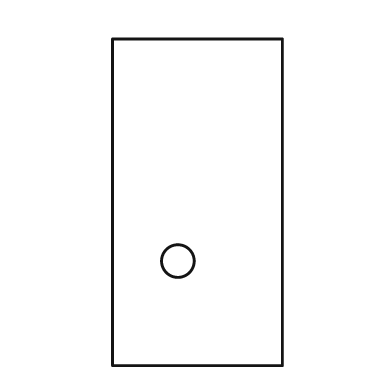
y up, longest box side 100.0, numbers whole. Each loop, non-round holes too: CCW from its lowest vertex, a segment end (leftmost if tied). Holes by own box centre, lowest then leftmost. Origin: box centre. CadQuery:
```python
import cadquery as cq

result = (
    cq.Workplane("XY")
    .moveTo(-26.0, -50.0)
    .lineTo(26.0, -50.0)
    .lineTo(26.0, 50.0)
    .lineTo(-26.0, 50.0)
    .close()
    .moveTo(-6.0, -18.0)
    .circle(5.0)
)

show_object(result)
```